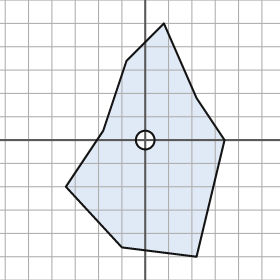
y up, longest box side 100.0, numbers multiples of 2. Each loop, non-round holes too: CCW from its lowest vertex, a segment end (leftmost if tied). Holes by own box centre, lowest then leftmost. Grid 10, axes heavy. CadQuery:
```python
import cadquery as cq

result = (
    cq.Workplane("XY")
    .moveTo(22.0, -50.0)
    .lineTo(34.0, 0.0)
    .lineTo(22.0, 18.0)
    .lineTo(8.0, 50.0)
    .lineTo(-8.0, 34.0)
    .lineTo(-18.0, 4.0)
    .lineTo(-34.0, -20.0)
    .lineTo(-10.0, -46.0)
    .close()
    .moveTo(0.0, 0.0)
    .circle(4.0)
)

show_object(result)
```